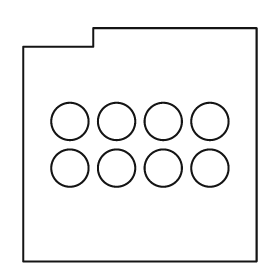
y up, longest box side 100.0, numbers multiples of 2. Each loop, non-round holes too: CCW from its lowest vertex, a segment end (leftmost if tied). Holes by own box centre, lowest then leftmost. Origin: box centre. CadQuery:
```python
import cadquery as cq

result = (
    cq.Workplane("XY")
    .moveTo(-50.0, -50.0)
    .lineTo(50.0, -50.0)
    .lineTo(50.0, 50.0)
    .lineTo(-20.0, 50.0)
    .lineTo(-20.0, 42.0)
    .lineTo(-50.0, 42.0)
    .close()
    .moveTo(-30.0, -10.0)
    .circle(8.0)
    .moveTo(-10.0, -10.0)
    .circle(8.0)
    .moveTo(10.0, -10.0)
    .circle(8.0)
    .moveTo(30.0, -10.0)
    .circle(8.0)
    .moveTo(-30.0, 10.0)
    .circle(8.0)
    .moveTo(-10.0, 10.0)
    .circle(8.0)
    .moveTo(10.0, 10.0)
    .circle(8.0)
    .moveTo(30.0, 10.0)
    .circle(8.0)
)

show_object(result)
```